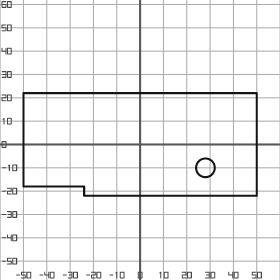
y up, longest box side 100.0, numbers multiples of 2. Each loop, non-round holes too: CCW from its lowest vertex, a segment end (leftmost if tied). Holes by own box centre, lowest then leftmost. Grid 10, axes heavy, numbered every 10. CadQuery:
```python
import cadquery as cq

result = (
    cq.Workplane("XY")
    .moveTo(-24.0, -22.0)
    .lineTo(50.0, -22.0)
    .lineTo(50.0, 22.0)
    .lineTo(-50.0, 22.0)
    .lineTo(-50.0, -18.0)
    .lineTo(-24.0, -18.0)
    .close()
    .moveTo(28.0, -10.0)
    .circle(4.0)
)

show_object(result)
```